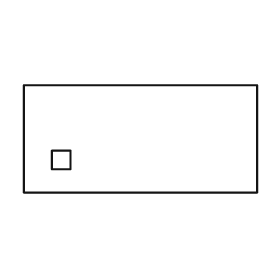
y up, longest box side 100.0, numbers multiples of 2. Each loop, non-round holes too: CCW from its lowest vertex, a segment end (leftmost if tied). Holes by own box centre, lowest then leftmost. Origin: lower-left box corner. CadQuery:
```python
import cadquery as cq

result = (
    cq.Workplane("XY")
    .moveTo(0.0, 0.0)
    .lineTo(100.0, 0.0)
    .lineTo(100.0, 46.0)
    .lineTo(0.0, 46.0)
    .close()
    .moveTo(12.0, 10.0)
    .lineTo(20.0, 10.0)
    .lineTo(20.0, 18.0)
    .lineTo(12.0, 18.0)
    .close()
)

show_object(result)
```